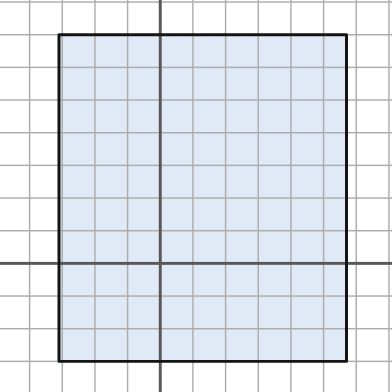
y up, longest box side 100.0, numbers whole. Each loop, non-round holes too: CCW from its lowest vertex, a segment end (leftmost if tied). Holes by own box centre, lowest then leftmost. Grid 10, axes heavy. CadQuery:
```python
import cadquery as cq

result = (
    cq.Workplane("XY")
    .moveTo(-31.0, -30.0)
    .lineTo(57.0, -30.0)
    .lineTo(57.0, 70.0)
    .lineTo(-31.0, 70.0)
    .close()
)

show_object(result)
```